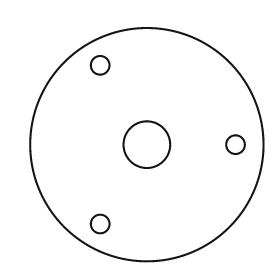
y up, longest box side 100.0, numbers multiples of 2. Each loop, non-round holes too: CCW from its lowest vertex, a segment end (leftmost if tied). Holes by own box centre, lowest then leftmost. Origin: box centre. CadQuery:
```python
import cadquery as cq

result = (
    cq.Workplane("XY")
    .moveTo(0.0, 0.0)
    .circle(50.0)
    .moveTo(-20.0, -34.0)
    .circle(4.0)
    .moveTo(0.0, 0.0)
    .circle(10.0)
    .moveTo(38.0, 0.0)
    .circle(4.0)
    .moveTo(-20.0, 34.0)
    .circle(4.0)
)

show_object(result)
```